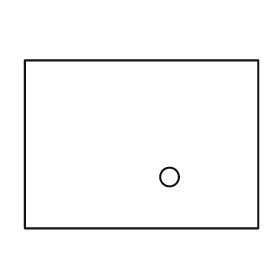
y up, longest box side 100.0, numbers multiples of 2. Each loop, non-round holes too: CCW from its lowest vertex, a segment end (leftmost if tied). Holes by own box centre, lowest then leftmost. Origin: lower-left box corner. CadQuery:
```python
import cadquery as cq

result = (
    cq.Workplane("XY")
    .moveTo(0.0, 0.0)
    .lineTo(100.0, 0.0)
    .lineTo(100.0, 72.0)
    .lineTo(0.0, 72.0)
    .close()
    .moveTo(62.0, 22.0)
    .circle(4.0)
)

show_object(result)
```